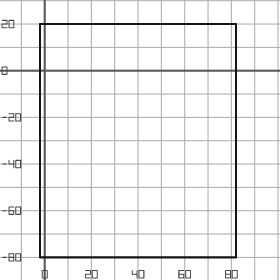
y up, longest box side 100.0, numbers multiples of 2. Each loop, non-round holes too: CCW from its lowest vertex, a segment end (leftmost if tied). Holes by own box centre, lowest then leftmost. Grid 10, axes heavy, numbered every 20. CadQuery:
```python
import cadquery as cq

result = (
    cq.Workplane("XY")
    .moveTo(-2.0, -80.0)
    .lineTo(82.0, -80.0)
    .lineTo(82.0, 20.0)
    .lineTo(-2.0, 20.0)
    .close()
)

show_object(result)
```